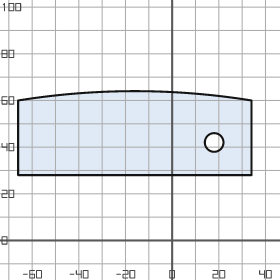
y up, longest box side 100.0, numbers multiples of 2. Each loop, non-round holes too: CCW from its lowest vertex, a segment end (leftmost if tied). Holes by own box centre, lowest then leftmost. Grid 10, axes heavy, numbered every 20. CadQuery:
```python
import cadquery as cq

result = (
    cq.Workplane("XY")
    .moveTo(-66.0, 28.0)
    .lineTo(34.0, 28.0)
    .lineTo(34.0, 60.0)
    .threePointArc((-16.0, 64.0), (-66.0, 60.0))
    .close()
    .moveTo(18.0, 42.0)
    .circle(4.0)
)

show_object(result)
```